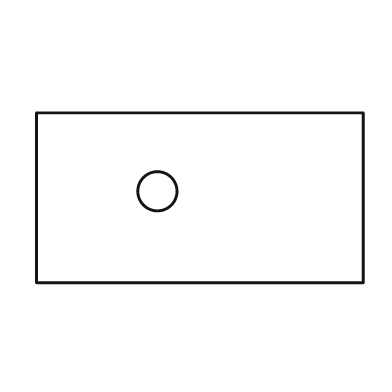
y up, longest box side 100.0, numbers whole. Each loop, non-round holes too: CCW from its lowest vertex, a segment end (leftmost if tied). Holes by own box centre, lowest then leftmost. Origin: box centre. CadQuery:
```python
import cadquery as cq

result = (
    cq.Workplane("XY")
    .moveTo(-50.0, -26.0)
    .lineTo(50.0, -26.0)
    .lineTo(50.0, 26.0)
    .lineTo(-50.0, 26.0)
    .close()
    .moveTo(-13.0, 2.0)
    .circle(6.0)
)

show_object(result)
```